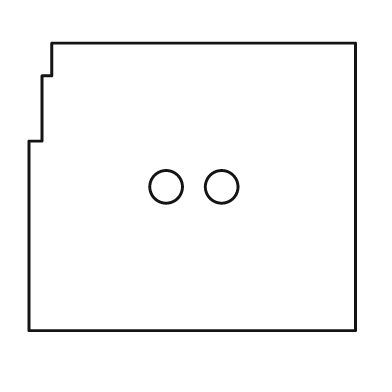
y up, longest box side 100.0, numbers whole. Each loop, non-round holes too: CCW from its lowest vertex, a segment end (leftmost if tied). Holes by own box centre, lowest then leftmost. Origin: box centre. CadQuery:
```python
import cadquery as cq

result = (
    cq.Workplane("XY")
    .moveTo(-50.0, -44.0)
    .lineTo(50.0, -44.0)
    .lineTo(50.0, 44.0)
    .lineTo(-43.0, 44.0)
    .lineTo(-43.0, 34.0)
    .lineTo(-46.0, 34.0)
    .lineTo(-46.0, 14.0)
    .lineTo(-50.0, 14.0)
    .close()
    .moveTo(-8.0, 0.0)
    .circle(5.0)
    .moveTo(9.0, 0.0)
    .circle(5.0)
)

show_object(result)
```